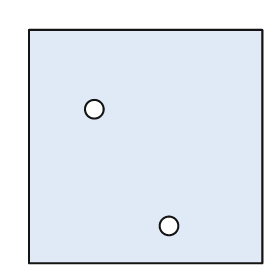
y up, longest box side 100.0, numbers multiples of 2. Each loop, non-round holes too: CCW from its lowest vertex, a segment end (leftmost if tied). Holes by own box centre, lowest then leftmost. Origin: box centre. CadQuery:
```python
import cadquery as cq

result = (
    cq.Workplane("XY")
    .moveTo(-50.0, -50.0)
    .lineTo(50.0, -50.0)
    .lineTo(50.0, 50.0)
    .lineTo(-50.0, 50.0)
    .close()
    .moveTo(10.0, -34.0)
    .circle(4.0)
    .moveTo(-22.0, 16.0)
    .circle(4.0)
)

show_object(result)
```